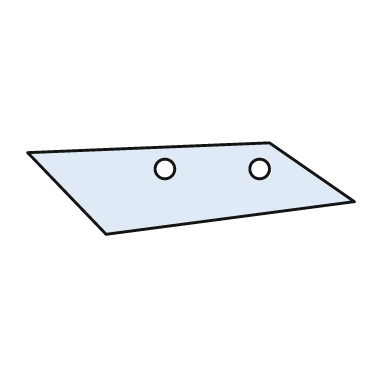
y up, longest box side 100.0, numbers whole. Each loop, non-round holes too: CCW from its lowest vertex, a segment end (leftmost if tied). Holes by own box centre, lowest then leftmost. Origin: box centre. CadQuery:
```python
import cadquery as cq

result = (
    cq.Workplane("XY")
    .moveTo(-26.0, -14.0)
    .lineTo(50.0, -4.0)
    .lineTo(24.0, 14.0)
    .lineTo(-50.0, 11.0)
    .close()
    .moveTo(-8.0, 6.0)
    .circle(3.0)
    .moveTo(21.0, 6.0)
    .circle(3.0)
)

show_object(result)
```